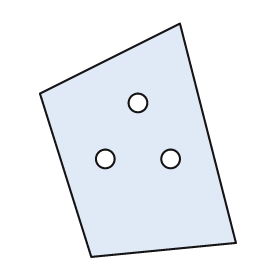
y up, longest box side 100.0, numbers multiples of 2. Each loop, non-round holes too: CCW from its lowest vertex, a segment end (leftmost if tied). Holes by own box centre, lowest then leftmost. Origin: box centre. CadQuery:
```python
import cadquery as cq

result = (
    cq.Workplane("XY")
    .moveTo(-20.0, -50.0)
    .lineTo(42.0, -44.0)
    .lineTo(18.0, 50.0)
    .lineTo(-42.0, 20.0)
    .close()
    .moveTo(-14.0, -8.0)
    .circle(4.0)
    .moveTo(14.0, -8.0)
    .circle(4.0)
    .moveTo(0.0, 16.0)
    .circle(4.0)
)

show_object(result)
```